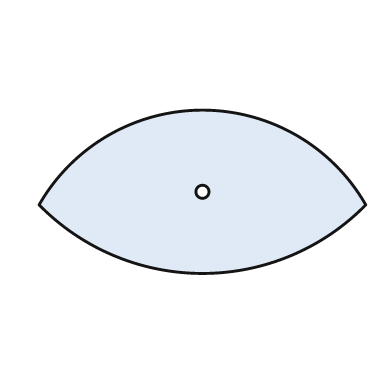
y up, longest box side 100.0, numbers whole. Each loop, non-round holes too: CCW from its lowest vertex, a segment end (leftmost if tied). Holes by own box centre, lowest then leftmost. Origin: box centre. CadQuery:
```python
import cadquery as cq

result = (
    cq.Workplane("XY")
    .moveTo(-50.0, -4.0)
    .threePointArc((0.0, -25.0), (50.0, -4.0))
    .threePointArc((0.0, 25.0), (-50.0, -4.0))
    .close()
    .moveTo(0.0, 0.0)
    .circle(2.0)
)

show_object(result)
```